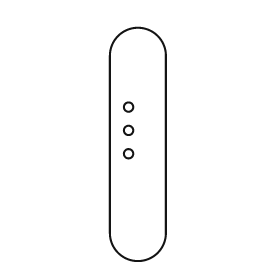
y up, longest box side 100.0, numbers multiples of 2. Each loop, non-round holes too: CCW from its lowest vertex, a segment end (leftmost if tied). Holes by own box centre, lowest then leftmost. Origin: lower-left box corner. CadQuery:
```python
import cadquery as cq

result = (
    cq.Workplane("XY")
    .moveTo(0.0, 12.0)
    .threePointArc((12.0, 0.0), (24.0, 12.0))
    .lineTo(24.0, 88.0)
    .threePointArc((12.0, 100.0), (0.0, 88.0))
    .close()
    .moveTo(8.0, 46.0)
    .circle(2.0)
    .moveTo(8.0, 56.0)
    .circle(2.0)
    .moveTo(8.0, 66.0)
    .circle(2.0)
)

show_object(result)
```